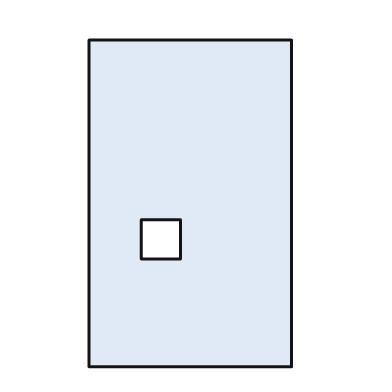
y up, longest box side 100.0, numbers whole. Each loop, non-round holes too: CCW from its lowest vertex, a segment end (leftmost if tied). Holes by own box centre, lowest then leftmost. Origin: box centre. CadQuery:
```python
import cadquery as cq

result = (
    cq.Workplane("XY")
    .moveTo(-31.0, -50.0)
    .lineTo(31.0, -50.0)
    .lineTo(31.0, 50.0)
    .lineTo(-31.0, 50.0)
    .close()
    .moveTo(-15.0, -17.0)
    .lineTo(-3.0, -17.0)
    .lineTo(-3.0, -5.0)
    .lineTo(-15.0, -5.0)
    .close()
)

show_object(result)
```